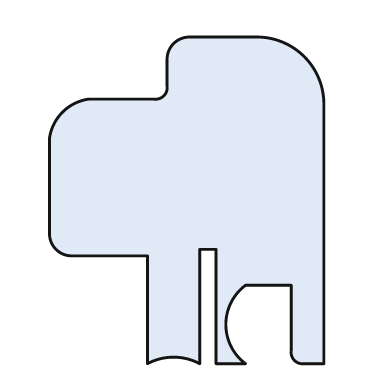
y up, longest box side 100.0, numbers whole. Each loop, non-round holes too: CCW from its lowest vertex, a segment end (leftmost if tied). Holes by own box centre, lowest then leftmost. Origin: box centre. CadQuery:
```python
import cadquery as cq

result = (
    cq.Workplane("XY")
    .moveTo(-12.0, -50.0)
    .threePointArc((-4.0, -48.0), (4.0, -50.0))
    .lineTo(4.0, -15.0)
    .lineTo(9.0, -15.0)
    .lineTo(9.0, -50.0)
    .lineTo(18.0, -50.0)
    .threePointArc((12.0, -38.0), (18.0, -26.0))
    .lineTo(32.0, -26.0)
    .lineTo(32.0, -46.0)
    .threePointArc((33.0, -49.0), (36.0, -50.0))
    .lineTo(42.0, -50.0)
    .lineTo(42.0, 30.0)
    .threePointArc((36.0, 44.0), (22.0, 50.0))
    .lineTo(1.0, 50.0)
    .threePointArc((-4.0, 48.0), (-6.0, 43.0))
    .lineTo(-6.0, 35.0)
    .threePointArc((-7.0, 32.0), (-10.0, 31.0))
    .lineTo(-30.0, 31.0)
    .threePointArc((-38.0, 27.0), (-42.0, 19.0))
    .lineTo(-42.0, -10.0)
    .threePointArc((-40.0, -15.0), (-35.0, -17.0))
    .lineTo(-12.0, -17.0)
    .close()
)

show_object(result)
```